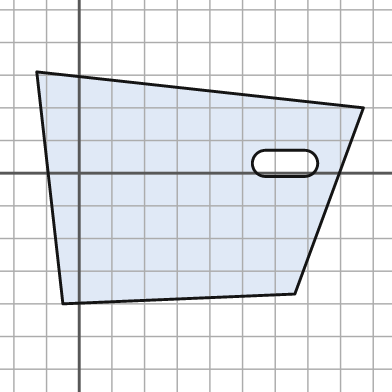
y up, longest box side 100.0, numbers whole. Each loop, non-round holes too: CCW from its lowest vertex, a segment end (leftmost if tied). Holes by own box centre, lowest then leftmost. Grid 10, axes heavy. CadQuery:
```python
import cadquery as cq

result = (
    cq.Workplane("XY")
    .moveTo(-5.0, -40.0)
    .lineTo(66.0, -37.0)
    .lineTo(87.0, 20.0)
    .lineTo(-13.0, 31.0)
    .close()
    .moveTo(57.0, -1.0)
    .lineTo(69.0, -1.0)
    .threePointArc((73.0, 3.0), (69.0, 7.0))
    .lineTo(57.0, 7.0)
    .threePointArc((53.0, 3.0), (57.0, -1.0))
    .close()
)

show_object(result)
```